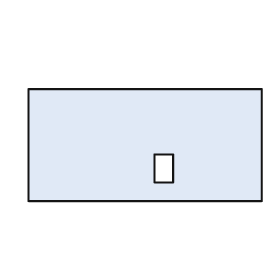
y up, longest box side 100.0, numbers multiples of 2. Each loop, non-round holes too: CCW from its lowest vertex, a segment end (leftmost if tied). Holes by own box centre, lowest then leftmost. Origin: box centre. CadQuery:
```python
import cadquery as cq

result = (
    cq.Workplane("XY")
    .moveTo(-50.0, -24.0)
    .lineTo(50.0, -24.0)
    .lineTo(50.0, 24.0)
    .lineTo(-50.0, 24.0)
    .close()
    .moveTo(4.0, -16.0)
    .lineTo(12.0, -16.0)
    .lineTo(12.0, -4.0)
    .lineTo(4.0, -4.0)
    .close()
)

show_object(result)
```